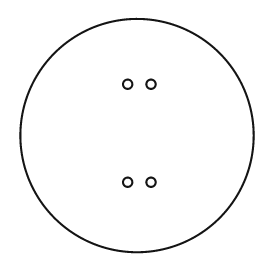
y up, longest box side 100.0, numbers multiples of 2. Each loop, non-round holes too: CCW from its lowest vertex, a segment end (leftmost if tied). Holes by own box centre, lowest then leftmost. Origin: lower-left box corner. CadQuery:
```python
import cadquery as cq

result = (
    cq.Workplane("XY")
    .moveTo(50.0, 50.0)
    .circle(50.0)
    .moveTo(46.0, 30.0)
    .circle(2.0)
    .moveTo(56.0, 30.0)
    .circle(2.0)
    .moveTo(46.0, 72.0)
    .circle(2.0)
    .moveTo(56.0, 72.0)
    .circle(2.0)
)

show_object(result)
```